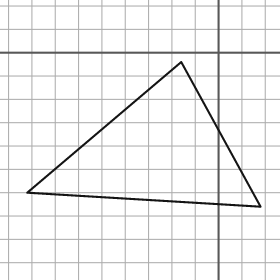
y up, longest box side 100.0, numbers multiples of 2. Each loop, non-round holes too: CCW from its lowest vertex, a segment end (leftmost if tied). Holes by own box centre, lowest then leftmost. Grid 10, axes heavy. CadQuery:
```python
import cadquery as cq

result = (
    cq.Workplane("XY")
    .moveTo(18.0, -66.0)
    .lineTo(-16.0, -4.0)
    .lineTo(-82.0, -60.0)
    .close()
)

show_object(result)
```